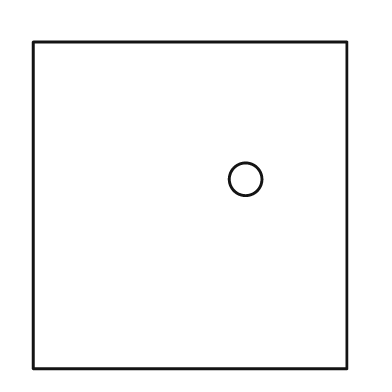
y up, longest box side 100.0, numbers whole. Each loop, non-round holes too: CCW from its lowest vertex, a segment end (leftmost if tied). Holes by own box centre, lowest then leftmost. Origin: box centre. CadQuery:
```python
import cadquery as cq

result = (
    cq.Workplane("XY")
    .moveTo(-48.0, -50.0)
    .lineTo(48.0, -50.0)
    .lineTo(48.0, 50.0)
    .lineTo(-48.0, 50.0)
    .close()
    .moveTo(17.0, 8.0)
    .circle(5.0)
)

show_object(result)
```